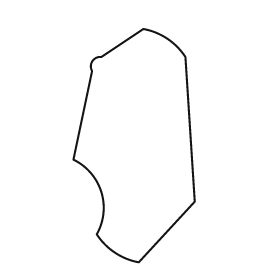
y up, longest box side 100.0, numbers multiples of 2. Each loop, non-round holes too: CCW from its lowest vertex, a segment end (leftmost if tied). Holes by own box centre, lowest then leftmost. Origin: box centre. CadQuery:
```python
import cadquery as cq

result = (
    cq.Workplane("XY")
    .moveTo(2.0, -50.0)
    .lineTo(26.0, -24.0)
    .lineTo(22.0, 38.0)
    .threePointArc((14.0, 46.0), (4.0, 50.0))
    .lineTo(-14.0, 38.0)
    .threePointArc((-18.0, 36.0), (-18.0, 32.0))
    .lineTo(-26.0, -6.0)
    .threePointArc((-14.0, -20.0), (-16.0, -38.0))
    .threePointArc((-8.0, -46.0), (2.0, -50.0))
    .close()
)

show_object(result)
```